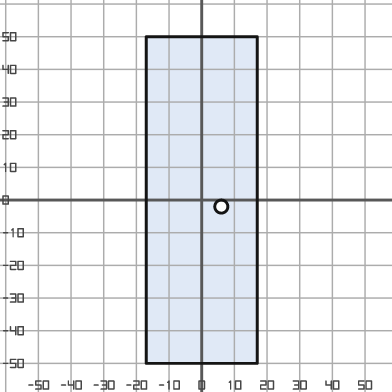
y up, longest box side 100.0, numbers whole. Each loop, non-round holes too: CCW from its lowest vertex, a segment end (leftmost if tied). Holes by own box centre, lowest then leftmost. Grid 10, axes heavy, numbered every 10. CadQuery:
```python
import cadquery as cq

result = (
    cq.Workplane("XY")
    .moveTo(-17.0, -50.0)
    .lineTo(17.0, -50.0)
    .lineTo(17.0, 50.0)
    .lineTo(-17.0, 50.0)
    .close()
    .moveTo(6.0, -2.0)
    .circle(2.0)
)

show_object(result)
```